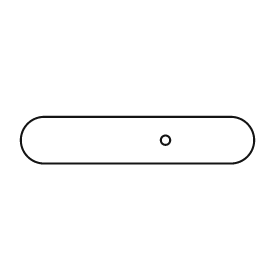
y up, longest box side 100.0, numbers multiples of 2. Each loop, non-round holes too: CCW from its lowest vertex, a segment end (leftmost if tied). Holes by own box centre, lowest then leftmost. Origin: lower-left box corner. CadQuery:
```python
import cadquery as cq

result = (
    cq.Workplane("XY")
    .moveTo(10.0, 0.0)
    .lineTo(90.0, 0.0)
    .threePointArc((100.0, 10.0), (90.0, 20.0))
    .lineTo(10.0, 20.0)
    .threePointArc((0.0, 10.0), (10.0, 0.0))
    .close()
    .moveTo(62.0, 10.0)
    .circle(2.0)
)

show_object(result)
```